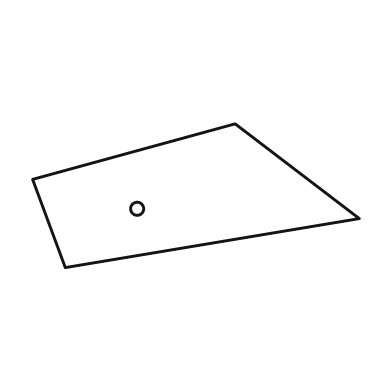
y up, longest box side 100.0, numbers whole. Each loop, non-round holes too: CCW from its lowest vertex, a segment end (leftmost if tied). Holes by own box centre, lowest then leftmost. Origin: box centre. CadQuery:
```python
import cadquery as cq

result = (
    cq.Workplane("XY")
    .moveTo(-40.0, -22.0)
    .lineTo(50.0, -7.0)
    .lineTo(12.0, 22.0)
    .lineTo(-50.0, 5.0)
    .close()
    .moveTo(-18.0, -4.0)
    .circle(2.0)
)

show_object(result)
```